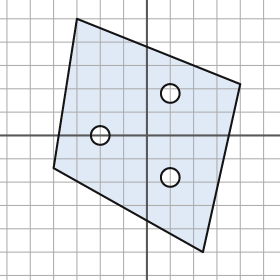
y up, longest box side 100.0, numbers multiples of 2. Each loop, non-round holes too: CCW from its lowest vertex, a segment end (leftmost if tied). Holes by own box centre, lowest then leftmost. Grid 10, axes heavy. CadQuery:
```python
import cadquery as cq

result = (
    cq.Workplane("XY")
    .moveTo(24.0, -50.0)
    .lineTo(40.0, 22.0)
    .lineTo(-30.0, 50.0)
    .lineTo(-40.0, -14.0)
    .close()
    .moveTo(10.0, -18.0)
    .circle(4.0)
    .moveTo(-20.0, 0.0)
    .circle(4.0)
    .moveTo(10.0, 18.0)
    .circle(4.0)
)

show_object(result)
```